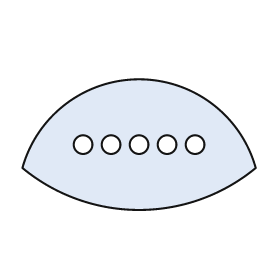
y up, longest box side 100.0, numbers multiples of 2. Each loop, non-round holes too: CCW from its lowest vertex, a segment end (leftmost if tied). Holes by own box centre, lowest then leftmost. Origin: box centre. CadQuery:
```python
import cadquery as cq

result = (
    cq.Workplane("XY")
    .moveTo(-50.0, -10.0)
    .threePointArc((0.0, -28.0), (50.0, -10.0))
    .threePointArc((0.0, 28.0), (-50.0, -10.0))
    .close()
    .moveTo(-24.0, 0.0)
    .circle(4.0)
    .moveTo(-12.0, 0.0)
    .circle(4.0)
    .moveTo(0.0, 0.0)
    .circle(4.0)
    .moveTo(12.0, 0.0)
    .circle(4.0)
    .moveTo(24.0, 0.0)
    .circle(4.0)
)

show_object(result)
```